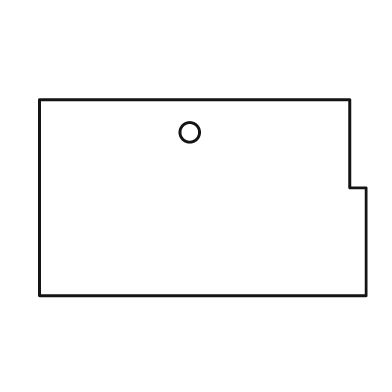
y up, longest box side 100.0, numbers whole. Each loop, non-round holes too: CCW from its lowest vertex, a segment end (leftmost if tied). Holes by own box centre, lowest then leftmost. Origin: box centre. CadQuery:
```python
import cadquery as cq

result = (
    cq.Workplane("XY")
    .moveTo(-50.0, -30.0)
    .lineTo(50.0, -30.0)
    .lineTo(50.0, 3.0)
    .lineTo(45.0, 3.0)
    .lineTo(45.0, 30.0)
    .lineTo(-50.0, 30.0)
    .close()
    .moveTo(-4.0, 20.0)
    .circle(3.0)
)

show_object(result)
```